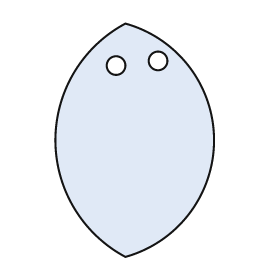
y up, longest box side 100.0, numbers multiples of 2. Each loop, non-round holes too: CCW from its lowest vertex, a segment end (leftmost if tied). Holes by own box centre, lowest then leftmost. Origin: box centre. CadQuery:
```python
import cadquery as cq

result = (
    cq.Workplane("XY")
    .moveTo(-4.0, -50.0)
    .threePointArc((34.0, 0.0), (-4.0, 50.0))
    .threePointArc((-34.0, 0.0), (-4.0, -50.0))
    .close()
    .moveTo(-8.0, 32.0)
    .circle(4.0)
    .moveTo(10.0, 34.0)
    .circle(4.0)
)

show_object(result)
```